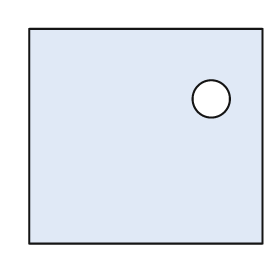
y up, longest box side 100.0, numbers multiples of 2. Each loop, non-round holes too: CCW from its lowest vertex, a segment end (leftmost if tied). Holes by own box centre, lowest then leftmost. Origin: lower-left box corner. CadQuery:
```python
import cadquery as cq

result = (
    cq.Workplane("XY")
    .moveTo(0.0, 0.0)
    .lineTo(100.0, 0.0)
    .lineTo(100.0, 92.0)
    .lineTo(0.0, 92.0)
    .close()
    .moveTo(78.0, 62.0)
    .circle(8.0)
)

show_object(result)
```